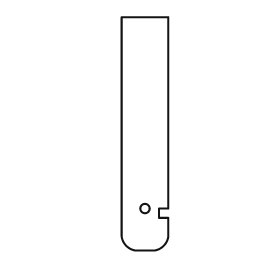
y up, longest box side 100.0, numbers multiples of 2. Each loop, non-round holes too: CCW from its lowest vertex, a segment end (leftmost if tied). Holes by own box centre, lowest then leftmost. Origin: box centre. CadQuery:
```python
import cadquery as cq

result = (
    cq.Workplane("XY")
    .moveTo(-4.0, -50.0)
    .lineTo(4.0, -50.0)
    .threePointArc((8.0, -48.0), (10.0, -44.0))
    .lineTo(10.0, -36.0)
    .lineTo(6.0, -36.0)
    .lineTo(6.0, -32.0)
    .lineTo(10.0, -32.0)
    .lineTo(10.0, 50.0)
    .lineTo(-10.0, 50.0)
    .lineTo(-10.0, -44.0)
    .threePointArc((-8.0, -48.0), (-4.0, -50.0))
    .close()
    .moveTo(0.0, -32.0)
    .circle(2.0)
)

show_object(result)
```